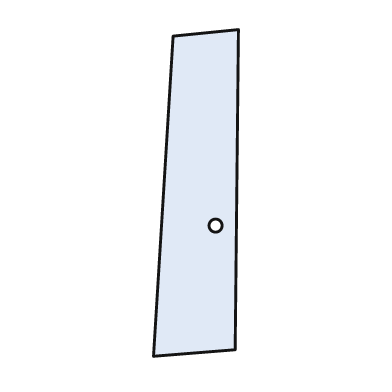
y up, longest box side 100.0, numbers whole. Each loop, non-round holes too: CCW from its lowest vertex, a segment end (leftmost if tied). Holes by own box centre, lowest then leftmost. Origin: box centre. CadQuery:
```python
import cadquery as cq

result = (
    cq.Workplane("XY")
    .moveTo(-13.0, -50.0)
    .lineTo(12.0, -48.0)
    .lineTo(13.0, 50.0)
    .lineTo(-7.0, 48.0)
    .close()
    .moveTo(6.0, -10.0)
    .circle(2.0)
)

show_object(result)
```